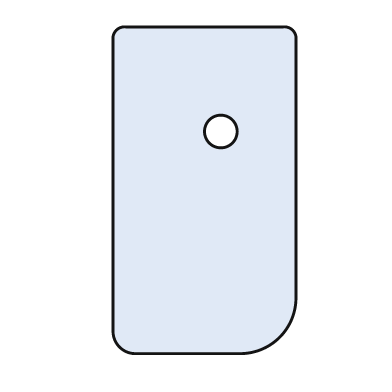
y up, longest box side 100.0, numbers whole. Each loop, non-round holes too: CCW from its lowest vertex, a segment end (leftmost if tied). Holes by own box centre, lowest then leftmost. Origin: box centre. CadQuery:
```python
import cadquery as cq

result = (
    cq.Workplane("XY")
    .moveTo(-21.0, -50.0)
    .lineTo(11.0, -50.0)
    .threePointArc((23.0, -45.0), (28.0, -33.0))
    .lineTo(28.0, 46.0)
    .threePointArc((27.0, 49.0), (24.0, 50.0))
    .lineTo(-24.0, 50.0)
    .threePointArc((-27.0, 49.0), (-28.0, 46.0))
    .lineTo(-28.0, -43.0)
    .threePointArc((-26.0, -48.0), (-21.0, -50.0))
    .close()
    .moveTo(5.0, 18.0)
    .circle(5.0)
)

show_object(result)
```